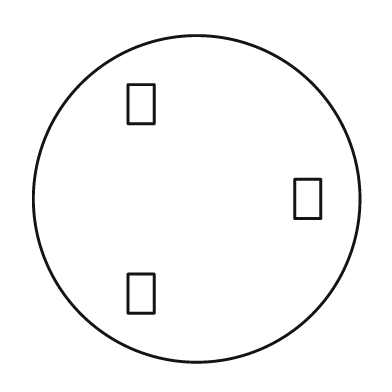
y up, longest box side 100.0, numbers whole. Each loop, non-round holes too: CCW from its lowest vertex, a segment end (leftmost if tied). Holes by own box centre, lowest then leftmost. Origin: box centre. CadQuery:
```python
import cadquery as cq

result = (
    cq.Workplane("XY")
    .moveTo(0.0, 0.0)
    .circle(50.0)
    .moveTo(-21.0, -35.0)
    .lineTo(-13.0, -35.0)
    .lineTo(-13.0, -23.0)
    .lineTo(-21.0, -23.0)
    .close()
    .moveTo(30.0, -6.0)
    .lineTo(38.0, -6.0)
    .lineTo(38.0, 6.0)
    .lineTo(30.0, 6.0)
    .close()
    .moveTo(-21.0, 23.0)
    .lineTo(-13.0, 23.0)
    .lineTo(-13.0, 35.0)
    .lineTo(-21.0, 35.0)
    .close()
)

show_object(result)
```